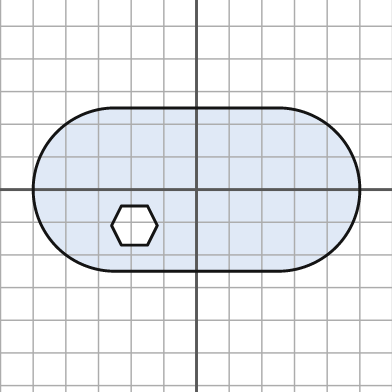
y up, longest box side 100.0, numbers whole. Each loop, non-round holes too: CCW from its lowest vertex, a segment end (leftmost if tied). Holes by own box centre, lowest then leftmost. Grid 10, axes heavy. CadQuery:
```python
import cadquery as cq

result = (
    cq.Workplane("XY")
    .moveTo(-25.0, -25.0)
    .lineTo(25.0, -25.0)
    .threePointArc((50.0, 0.0), (25.0, 25.0))
    .lineTo(-25.0, 25.0)
    .threePointArc((-50.0, 0.0), (-25.0, -25.0))
    .close()
    .moveTo(-23.0, -17.0)
    .lineTo(-15.0, -17.0)
    .lineTo(-12.0, -11.0)
    .lineTo(-15.0, -5.0)
    .lineTo(-23.0, -5.0)
    .lineTo(-26.0, -11.0)
    .close()
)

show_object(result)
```